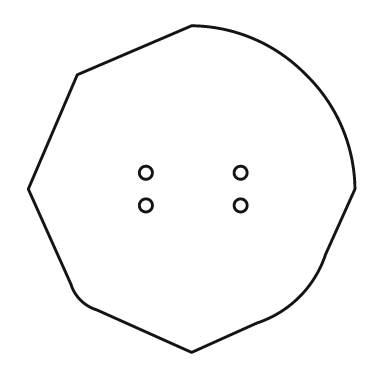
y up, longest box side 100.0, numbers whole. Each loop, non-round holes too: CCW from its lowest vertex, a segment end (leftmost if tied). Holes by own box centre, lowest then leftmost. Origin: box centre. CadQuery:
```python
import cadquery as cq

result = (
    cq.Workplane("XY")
    .moveTo(0.0, -50.0)
    .lineTo(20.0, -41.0)
    .threePointArc((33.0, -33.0), (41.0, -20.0))
    .lineTo(50.0, 0.0)
    .threePointArc((46.0, 19.0), (35.0, 35.0))
    .threePointArc((19.0, 46.0), (0.0, 50.0))
    .lineTo(-35.0, 35.0)
    .lineTo(-50.0, 0.0)
    .lineTo(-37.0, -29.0)
    .threePointArc((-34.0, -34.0), (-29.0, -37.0))
    .close()
    .moveTo(-14.0, -5.0)
    .circle(2.0)
    .moveTo(15.0, -5.0)
    .circle(2.0)
    .moveTo(-14.0, 5.0)
    .circle(2.0)
    .moveTo(15.0, 5.0)
    .circle(2.0)
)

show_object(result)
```